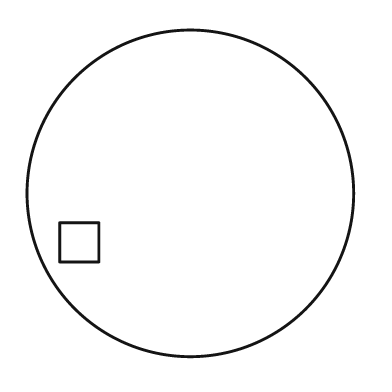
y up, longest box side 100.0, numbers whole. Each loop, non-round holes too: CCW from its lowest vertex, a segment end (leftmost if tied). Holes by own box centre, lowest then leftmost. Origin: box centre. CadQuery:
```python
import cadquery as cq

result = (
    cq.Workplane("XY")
    .moveTo(0.0, 0.0)
    .circle(50.0)
    .moveTo(-40.0, -21.0)
    .lineTo(-28.0, -21.0)
    .lineTo(-28.0, -9.0)
    .lineTo(-40.0, -9.0)
    .close()
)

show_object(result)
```